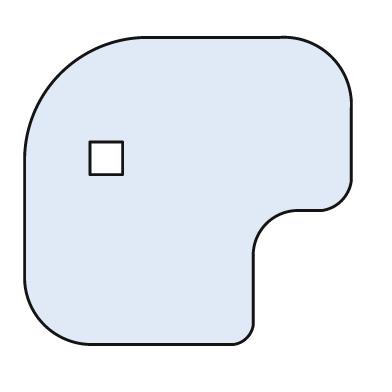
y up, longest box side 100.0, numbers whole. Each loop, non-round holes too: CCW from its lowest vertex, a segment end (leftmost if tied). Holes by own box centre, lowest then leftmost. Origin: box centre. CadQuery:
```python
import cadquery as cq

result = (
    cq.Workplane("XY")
    .moveTo(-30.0, -47.0)
    .lineTo(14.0, -47.0)
    .threePointArc((18.0, -45.0), (20.0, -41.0))
    .lineTo(20.0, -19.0)
    .threePointArc((24.0, -10.0), (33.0, -6.0))
    .lineTo(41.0, -6.0)
    .threePointArc((47.0, -3.0), (50.0, 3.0))
    .lineTo(50.0, 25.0)
    .threePointArc((44.0, 41.0), (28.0, 47.0))
    .lineTo(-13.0, 47.0)
    .threePointArc((-39.0, 36.0), (-50.0, 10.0))
    .lineTo(-50.0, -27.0)
    .threePointArc((-44.0, -41.0), (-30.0, -47.0))
    .close()
    .moveTo(-30.0, 5.0)
    .lineTo(-20.0, 5.0)
    .lineTo(-20.0, 15.0)
    .lineTo(-30.0, 15.0)
    .close()
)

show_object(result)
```